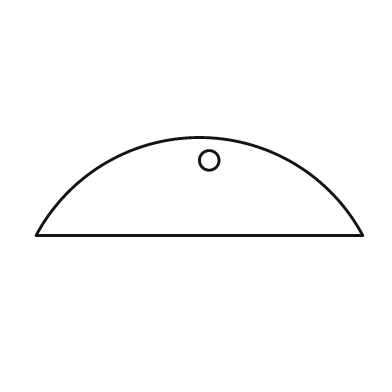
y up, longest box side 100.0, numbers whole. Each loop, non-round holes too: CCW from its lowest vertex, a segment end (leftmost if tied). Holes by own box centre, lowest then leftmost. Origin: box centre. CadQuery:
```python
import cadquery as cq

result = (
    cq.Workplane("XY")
    .moveTo(-50.0, -15.0)
    .lineTo(50.0, -15.0)
    .threePointArc((0.0, 15.0), (-50.0, -15.0))
    .close()
    .moveTo(3.0, 8.0)
    .circle(3.0)
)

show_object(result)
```